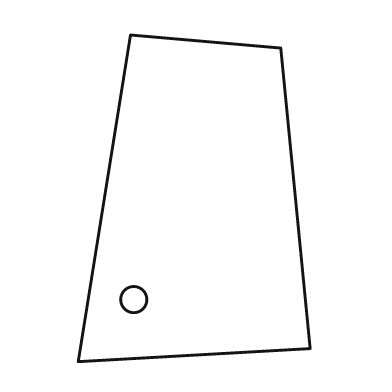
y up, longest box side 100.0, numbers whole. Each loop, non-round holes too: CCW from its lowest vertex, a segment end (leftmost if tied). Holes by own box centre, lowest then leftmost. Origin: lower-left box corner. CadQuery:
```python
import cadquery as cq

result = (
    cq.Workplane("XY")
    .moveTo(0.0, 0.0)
    .lineTo(71.0, 4.0)
    .lineTo(62.0, 96.0)
    .lineTo(16.0, 100.0)
    .close()
    .moveTo(17.0, 19.0)
    .circle(4.0)
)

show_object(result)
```